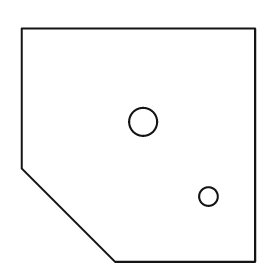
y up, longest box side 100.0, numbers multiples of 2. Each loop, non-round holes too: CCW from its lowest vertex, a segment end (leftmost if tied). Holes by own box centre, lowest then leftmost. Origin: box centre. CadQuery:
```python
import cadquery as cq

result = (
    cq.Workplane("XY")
    .moveTo(-10.0, -50.0)
    .lineTo(50.0, -50.0)
    .lineTo(50.0, 50.0)
    .lineTo(-50.0, 50.0)
    .lineTo(-50.0, -10.0)
    .close()
    .moveTo(30.0, -22.0)
    .circle(4.0)
    .moveTo(2.0, 10.0)
    .circle(6.0)
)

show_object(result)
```